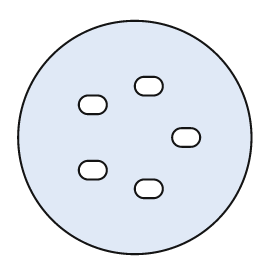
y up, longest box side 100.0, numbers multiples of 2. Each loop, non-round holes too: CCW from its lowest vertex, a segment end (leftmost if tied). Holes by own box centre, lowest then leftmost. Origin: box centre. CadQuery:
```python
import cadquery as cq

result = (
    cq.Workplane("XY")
    .moveTo(0.0, 0.0)
    .circle(50.0)
    .moveTo(4.0, -26.0)
    .lineTo(8.0, -26.0)
    .threePointArc((12.0, -22.0), (8.0, -18.0))
    .lineTo(4.0, -18.0)
    .threePointArc((0.0, -22.0), (4.0, -26.0))
    .close()
    .moveTo(-20.0, -18.0)
    .lineTo(-16.0, -18.0)
    .threePointArc((-12.0, -14.0), (-16.0, -10.0))
    .lineTo(-20.0, -10.0)
    .threePointArc((-24.0, -14.0), (-20.0, -18.0))
    .close()
    .moveTo(20.0, -4.0)
    .lineTo(24.0, -4.0)
    .threePointArc((28.0, 0.0), (24.0, 4.0))
    .lineTo(20.0, 4.0)
    .threePointArc((16.0, 0.0), (20.0, -4.0))
    .close()
    .moveTo(-20.0, 10.0)
    .lineTo(-16.0, 10.0)
    .threePointArc((-12.0, 14.0), (-16.0, 18.0))
    .lineTo(-20.0, 18.0)
    .threePointArc((-24.0, 14.0), (-20.0, 10.0))
    .close()
    .moveTo(4.0, 18.0)
    .lineTo(8.0, 18.0)
    .threePointArc((12.0, 22.0), (8.0, 26.0))
    .lineTo(4.0, 26.0)
    .threePointArc((0.0, 22.0), (4.0, 18.0))
    .close()
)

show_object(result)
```